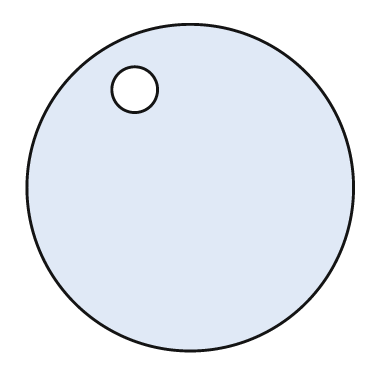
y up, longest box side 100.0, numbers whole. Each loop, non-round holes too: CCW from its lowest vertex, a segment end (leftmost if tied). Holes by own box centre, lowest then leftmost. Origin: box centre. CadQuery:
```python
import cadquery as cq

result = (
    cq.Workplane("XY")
    .moveTo(0.0, 0.0)
    .circle(50.0)
    .moveTo(-17.0, 30.0)
    .circle(7.0)
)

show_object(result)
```